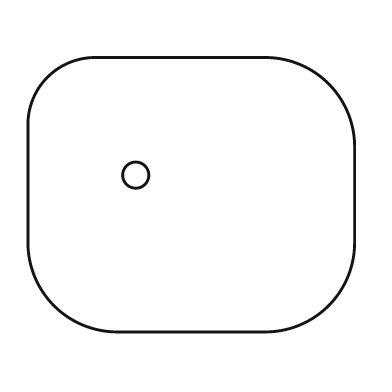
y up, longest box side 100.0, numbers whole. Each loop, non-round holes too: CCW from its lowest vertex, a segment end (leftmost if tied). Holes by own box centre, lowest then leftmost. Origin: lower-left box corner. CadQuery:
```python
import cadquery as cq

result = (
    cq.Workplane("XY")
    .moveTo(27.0, 0.0)
    .lineTo(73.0, 0.0)
    .threePointArc((92.0, 8.0), (100.0, 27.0))
    .lineTo(100.0, 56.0)
    .threePointArc((92.0, 76.0), (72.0, 84.0))
    .lineTo(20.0, 84.0)
    .threePointArc((6.0, 78.0), (0.0, 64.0))
    .lineTo(0.0, 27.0)
    .threePointArc((8.0, 8.0), (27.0, 0.0))
    .close()
    .moveTo(33.0, 48.0)
    .circle(4.0)
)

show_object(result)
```